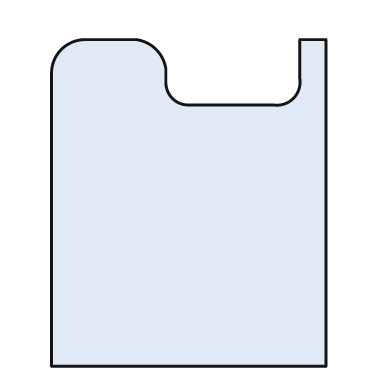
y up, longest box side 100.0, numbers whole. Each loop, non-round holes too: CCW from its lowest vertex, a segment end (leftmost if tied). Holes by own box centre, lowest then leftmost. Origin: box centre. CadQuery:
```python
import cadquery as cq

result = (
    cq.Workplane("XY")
    .moveTo(-42.0, -50.0)
    .lineTo(42.0, -50.0)
    .lineTo(42.0, 50.0)
    .lineTo(34.0, 50.0)
    .lineTo(34.0, 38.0)
    .threePointArc((32.0, 32.0), (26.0, 30.0))
    .lineTo(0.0, 30.0)
    .threePointArc((-5.0, 32.0), (-7.0, 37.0))
    .lineTo(-7.0, 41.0)
    .threePointArc((-10.0, 47.0), (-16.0, 50.0))
    .lineTo(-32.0, 50.0)
    .threePointArc((-39.0, 47.0), (-42.0, 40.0))
    .close()
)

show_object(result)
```